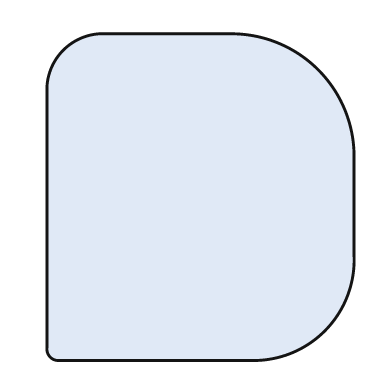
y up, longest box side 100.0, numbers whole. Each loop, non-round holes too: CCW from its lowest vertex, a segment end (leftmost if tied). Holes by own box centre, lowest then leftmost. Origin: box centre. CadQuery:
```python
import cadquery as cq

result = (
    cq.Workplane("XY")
    .moveTo(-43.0, -50.0)
    .lineTo(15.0, -50.0)
    .threePointArc((38.0, -41.0), (47.0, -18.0))
    .lineTo(47.0, 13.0)
    .threePointArc((36.0, 39.0), (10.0, 50.0))
    .lineTo(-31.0, 50.0)
    .threePointArc((-42.0, 45.0), (-47.0, 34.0))
    .lineTo(-47.0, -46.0)
    .threePointArc((-46.0, -49.0), (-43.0, -50.0))
    .close()
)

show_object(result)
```